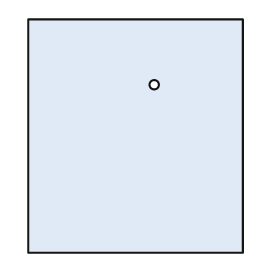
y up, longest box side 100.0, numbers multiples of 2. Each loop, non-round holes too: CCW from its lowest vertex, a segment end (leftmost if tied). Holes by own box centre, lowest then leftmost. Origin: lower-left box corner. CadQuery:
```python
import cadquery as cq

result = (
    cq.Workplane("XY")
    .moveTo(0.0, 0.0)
    .lineTo(92.0, 0.0)
    .lineTo(92.0, 100.0)
    .lineTo(0.0, 100.0)
    .close()
    .moveTo(54.0, 72.0)
    .circle(2.0)
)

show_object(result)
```